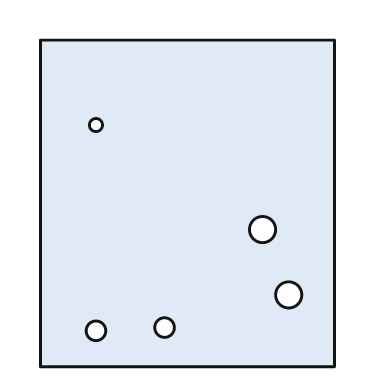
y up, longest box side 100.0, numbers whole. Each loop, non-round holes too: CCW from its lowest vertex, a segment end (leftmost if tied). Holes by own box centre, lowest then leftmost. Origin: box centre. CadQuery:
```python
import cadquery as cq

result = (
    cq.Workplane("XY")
    .moveTo(-45.0, -50.0)
    .lineTo(45.0, -50.0)
    .lineTo(45.0, 50.0)
    .lineTo(-45.0, 50.0)
    .close()
    .moveTo(-28.0, -39.0)
    .circle(3.0)
    .moveTo(-7.0, -38.0)
    .circle(3.0)
    .moveTo(31.0, -28.0)
    .circle(4.0)
    .moveTo(23.0, -8.0)
    .circle(4.0)
    .moveTo(-28.0, 24.0)
    .circle(2.0)
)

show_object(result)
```